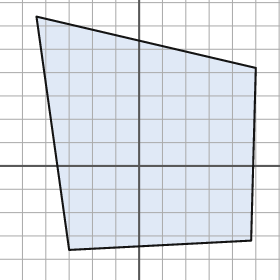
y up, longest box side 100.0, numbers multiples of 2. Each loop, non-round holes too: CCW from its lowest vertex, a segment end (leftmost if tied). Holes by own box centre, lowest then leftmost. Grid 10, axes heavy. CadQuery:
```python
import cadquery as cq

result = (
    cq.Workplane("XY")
    .moveTo(-30.0, -36.0)
    .lineTo(48.0, -32.0)
    .lineTo(50.0, 42.0)
    .lineTo(-44.0, 64.0)
    .close()
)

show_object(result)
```